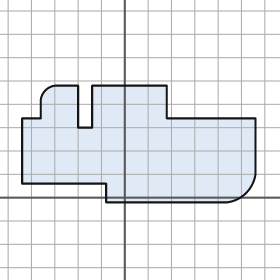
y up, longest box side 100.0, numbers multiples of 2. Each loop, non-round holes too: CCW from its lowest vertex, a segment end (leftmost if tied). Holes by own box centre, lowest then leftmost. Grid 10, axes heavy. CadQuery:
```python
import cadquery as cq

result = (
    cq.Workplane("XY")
    .moveTo(-8.0, -2.0)
    .lineTo(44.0, -2.0)
    .threePointArc((52.0, 2.0), (56.0, 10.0))
    .lineTo(56.0, 34.0)
    .lineTo(18.0, 34.0)
    .lineTo(18.0, 48.0)
    .lineTo(-14.0, 48.0)
    .lineTo(-14.0, 30.0)
    .lineTo(-20.0, 30.0)
    .lineTo(-20.0, 48.0)
    .lineTo(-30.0, 48.0)
    .threePointArc((-34.0, 46.0), (-36.0, 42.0))
    .lineTo(-36.0, 34.0)
    .lineTo(-44.0, 34.0)
    .lineTo(-44.0, 6.0)
    .lineTo(-8.0, 6.0)
    .close()
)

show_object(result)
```